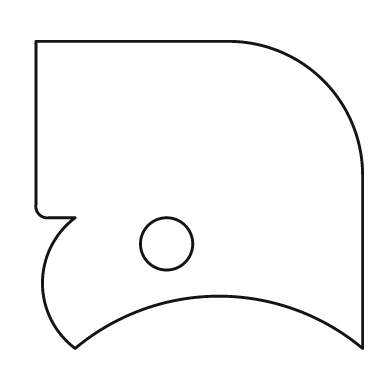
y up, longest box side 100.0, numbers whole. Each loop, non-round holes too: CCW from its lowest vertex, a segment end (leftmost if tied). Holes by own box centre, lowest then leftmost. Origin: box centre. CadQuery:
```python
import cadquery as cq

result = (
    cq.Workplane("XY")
    .moveTo(-38.0, -47.0)
    .threePointArc((6.0, -31.0), (50.0, -47.0))
    .lineTo(50.0, 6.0)
    .threePointArc((38.0, 35.0), (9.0, 47.0))
    .lineTo(-50.0, 47.0)
    .lineTo(-50.0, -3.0)
    .threePointArc((-49.0, -6.0), (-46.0, -7.0))
    .lineTo(-38.0, -7.0)
    .threePointArc((-48.0, -27.0), (-38.0, -47.0))
    .close()
    .moveTo(-10.0, -15.0)
    .circle(8.0)
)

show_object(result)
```